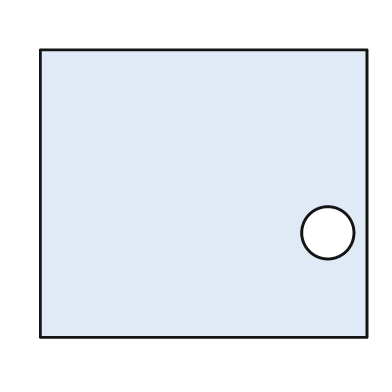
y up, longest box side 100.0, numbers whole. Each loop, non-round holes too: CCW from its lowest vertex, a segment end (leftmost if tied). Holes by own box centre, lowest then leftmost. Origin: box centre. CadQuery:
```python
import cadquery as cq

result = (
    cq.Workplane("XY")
    .moveTo(-50.0, -44.0)
    .lineTo(50.0, -44.0)
    .lineTo(50.0, 44.0)
    .lineTo(-50.0, 44.0)
    .close()
    .moveTo(38.0, -12.0)
    .circle(8.0)
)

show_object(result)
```